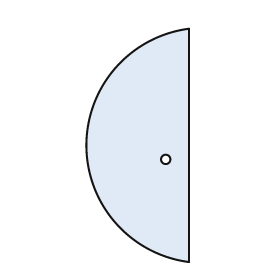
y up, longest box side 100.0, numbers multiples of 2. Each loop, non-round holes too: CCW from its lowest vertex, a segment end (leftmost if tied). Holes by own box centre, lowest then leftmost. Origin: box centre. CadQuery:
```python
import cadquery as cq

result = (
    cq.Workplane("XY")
    .moveTo(22.0, -50.0)
    .lineTo(22.0, 50.0)
    .threePointArc((-22.0, 0.0), (22.0, -50.0))
    .close()
    .moveTo(12.0, -6.0)
    .circle(2.0)
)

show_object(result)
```